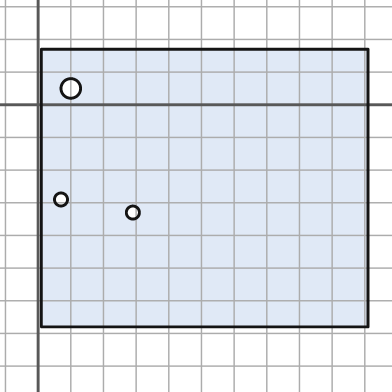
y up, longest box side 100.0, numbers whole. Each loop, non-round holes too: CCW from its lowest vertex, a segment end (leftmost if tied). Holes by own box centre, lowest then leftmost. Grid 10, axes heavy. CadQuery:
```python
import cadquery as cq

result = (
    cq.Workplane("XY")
    .moveTo(1.0, -68.0)
    .lineTo(101.0, -68.0)
    .lineTo(101.0, 17.0)
    .lineTo(1.0, 17.0)
    .close()
    .moveTo(29.0, -33.0)
    .circle(2.0)
    .moveTo(7.0, -29.0)
    .circle(2.0)
    .moveTo(10.0, 5.0)
    .circle(3.0)
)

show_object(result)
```